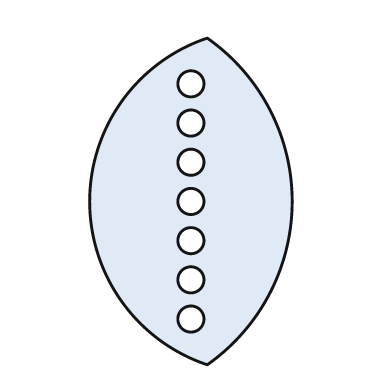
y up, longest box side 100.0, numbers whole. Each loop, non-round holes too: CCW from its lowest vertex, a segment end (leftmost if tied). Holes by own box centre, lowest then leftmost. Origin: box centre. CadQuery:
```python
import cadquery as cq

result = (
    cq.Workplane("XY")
    .moveTo(5.0, -50.0)
    .threePointArc((31.0, 0.0), (5.0, 50.0))
    .threePointArc((-31.0, 0.0), (5.0, -50.0))
    .close()
    .moveTo(0.0, -36.0)
    .circle(4.0)
    .moveTo(0.0, -24.0)
    .circle(4.0)
    .moveTo(0.0, -12.0)
    .circle(4.0)
    .moveTo(0.0, 0.0)
    .circle(4.0)
    .moveTo(0.0, 12.0)
    .circle(4.0)
    .moveTo(0.0, 24.0)
    .circle(4.0)
    .moveTo(0.0, 36.0)
    .circle(4.0)
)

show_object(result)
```